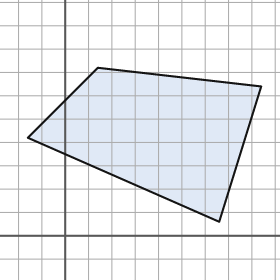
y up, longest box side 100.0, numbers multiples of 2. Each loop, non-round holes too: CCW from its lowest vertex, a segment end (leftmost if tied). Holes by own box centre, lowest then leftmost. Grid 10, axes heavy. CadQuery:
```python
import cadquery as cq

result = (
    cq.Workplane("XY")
    .moveTo(66.0, 6.0)
    .lineTo(84.0, 64.0)
    .lineTo(14.0, 72.0)
    .lineTo(-16.0, 42.0)
    .close()
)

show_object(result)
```